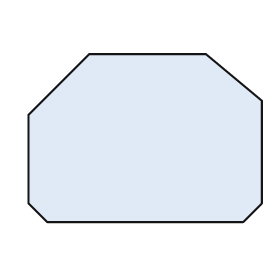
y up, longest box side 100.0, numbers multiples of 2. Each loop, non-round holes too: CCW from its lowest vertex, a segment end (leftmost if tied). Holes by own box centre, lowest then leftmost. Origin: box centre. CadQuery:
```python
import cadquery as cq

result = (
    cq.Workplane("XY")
    .moveTo(-42.0, -36.0)
    .lineTo(42.0, -36.0)
    .lineTo(50.0, -28.0)
    .lineTo(50.0, 16.0)
    .lineTo(26.0, 36.0)
    .lineTo(-24.0, 36.0)
    .lineTo(-50.0, 10.0)
    .lineTo(-50.0, -28.0)
    .close()
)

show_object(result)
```